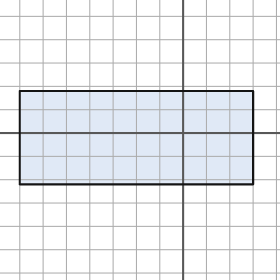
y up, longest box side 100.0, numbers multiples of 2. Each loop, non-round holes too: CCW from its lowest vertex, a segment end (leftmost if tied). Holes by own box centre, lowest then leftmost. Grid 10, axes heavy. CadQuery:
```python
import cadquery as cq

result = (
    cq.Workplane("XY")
    .moveTo(-70.0, -22.0)
    .lineTo(30.0, -22.0)
    .lineTo(30.0, 18.0)
    .lineTo(-70.0, 18.0)
    .close()
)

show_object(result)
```